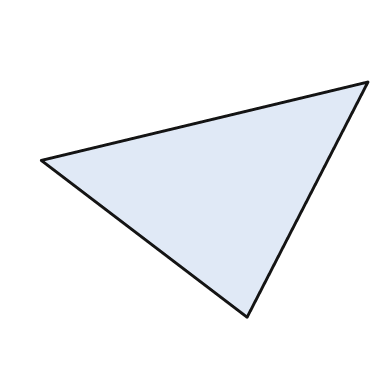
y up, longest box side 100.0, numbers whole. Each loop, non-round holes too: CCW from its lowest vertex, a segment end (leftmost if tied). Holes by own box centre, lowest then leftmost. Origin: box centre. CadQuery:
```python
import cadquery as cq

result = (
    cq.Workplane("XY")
    .moveTo(13.0, -36.0)
    .lineTo(50.0, 36.0)
    .lineTo(-50.0, 12.0)
    .close()
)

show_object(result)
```